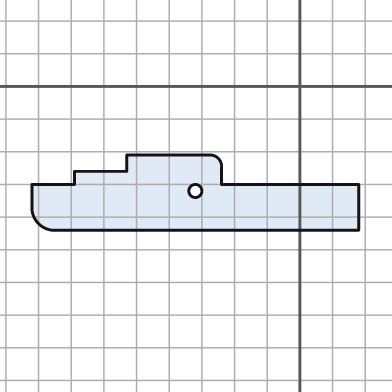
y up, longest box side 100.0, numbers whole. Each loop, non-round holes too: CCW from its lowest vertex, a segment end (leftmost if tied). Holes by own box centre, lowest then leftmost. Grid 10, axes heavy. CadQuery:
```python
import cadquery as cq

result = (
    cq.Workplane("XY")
    .moveTo(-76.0, -44.0)
    .lineTo(18.0, -44.0)
    .lineTo(18.0, -30.0)
    .lineTo(-24.0, -30.0)
    .lineTo(-24.0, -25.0)
    .threePointArc((-25.0, -22.0), (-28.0, -21.0))
    .lineTo(-53.0, -21.0)
    .lineTo(-53.0, -26.0)
    .lineTo(-69.0, -26.0)
    .lineTo(-69.0, -30.0)
    .lineTo(-82.0, -30.0)
    .lineTo(-82.0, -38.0)
    .threePointArc((-80.0, -42.0), (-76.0, -44.0))
    .close()
    .moveTo(-32.0, -32.0)
    .circle(2.0)
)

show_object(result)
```